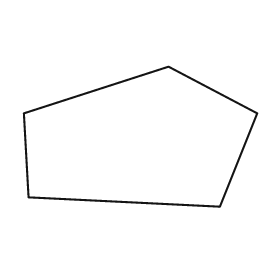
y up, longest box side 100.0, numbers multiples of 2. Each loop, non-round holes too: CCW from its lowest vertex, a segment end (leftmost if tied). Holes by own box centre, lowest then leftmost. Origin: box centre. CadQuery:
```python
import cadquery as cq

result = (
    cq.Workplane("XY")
    .moveTo(34.0, -30.0)
    .lineTo(50.0, 10.0)
    .lineTo(12.0, 30.0)
    .lineTo(-50.0, 10.0)
    .lineTo(-48.0, -26.0)
    .close()
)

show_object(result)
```